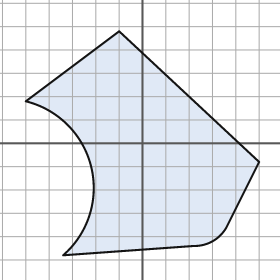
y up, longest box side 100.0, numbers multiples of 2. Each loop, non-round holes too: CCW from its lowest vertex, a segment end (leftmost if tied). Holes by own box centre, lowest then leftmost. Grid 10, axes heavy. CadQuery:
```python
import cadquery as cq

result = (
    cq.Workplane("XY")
    .moveTo(-34.0, -48.0)
    .lineTo(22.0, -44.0)
    .threePointArc((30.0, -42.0), (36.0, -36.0))
    .lineTo(50.0, -8.0)
    .lineTo(-10.0, 48.0)
    .lineTo(-50.0, 18.0)
    .threePointArc((-22.0, -10.0), (-34.0, -48.0))
    .close()
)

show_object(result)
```